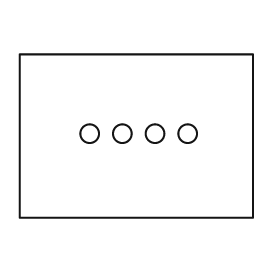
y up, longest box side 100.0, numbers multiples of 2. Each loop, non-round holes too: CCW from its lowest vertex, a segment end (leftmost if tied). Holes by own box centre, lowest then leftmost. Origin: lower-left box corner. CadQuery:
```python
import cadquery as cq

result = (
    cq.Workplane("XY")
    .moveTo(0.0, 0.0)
    .lineTo(100.0, 0.0)
    .lineTo(100.0, 70.0)
    .lineTo(0.0, 70.0)
    .close()
    .moveTo(30.0, 36.0)
    .circle(4.0)
    .moveTo(44.0, 36.0)
    .circle(4.0)
    .moveTo(58.0, 36.0)
    .circle(4.0)
    .moveTo(72.0, 36.0)
    .circle(4.0)
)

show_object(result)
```